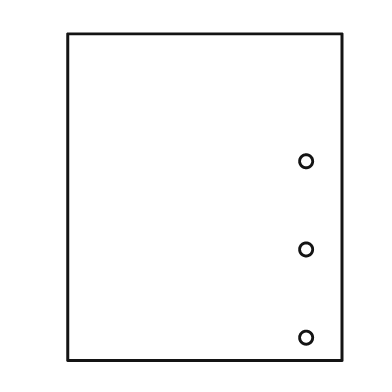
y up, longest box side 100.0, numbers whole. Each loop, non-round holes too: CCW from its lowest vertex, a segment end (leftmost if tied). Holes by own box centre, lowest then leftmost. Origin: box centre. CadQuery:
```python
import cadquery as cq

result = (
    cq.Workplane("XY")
    .moveTo(-42.0, -50.0)
    .lineTo(42.0, -50.0)
    .lineTo(42.0, 50.0)
    .lineTo(-42.0, 50.0)
    .close()
    .moveTo(31.0, -43.0)
    .circle(2.0)
    .moveTo(31.0, -16.0)
    .circle(2.0)
    .moveTo(31.0, 11.0)
    .circle(2.0)
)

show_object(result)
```